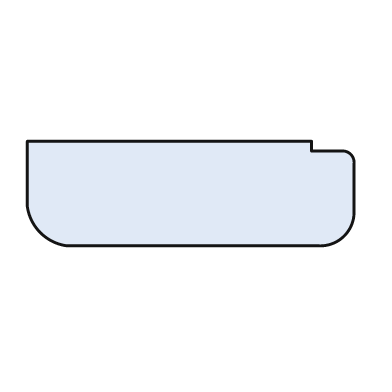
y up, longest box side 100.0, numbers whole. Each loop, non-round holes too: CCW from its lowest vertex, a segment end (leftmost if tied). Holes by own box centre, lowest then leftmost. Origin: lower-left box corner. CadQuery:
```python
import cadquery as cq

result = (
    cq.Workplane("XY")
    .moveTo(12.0, 0.0)
    .lineTo(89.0, 0.0)
    .threePointArc((97.0, 3.0), (100.0, 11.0))
    .lineTo(100.0, 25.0)
    .threePointArc((99.0, 28.0), (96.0, 29.0))
    .lineTo(87.0, 29.0)
    .lineTo(87.0, 32.0)
    .lineTo(0.0, 32.0)
    .lineTo(0.0, 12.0)
    .threePointArc((4.0, 4.0), (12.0, 0.0))
    .close()
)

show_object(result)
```